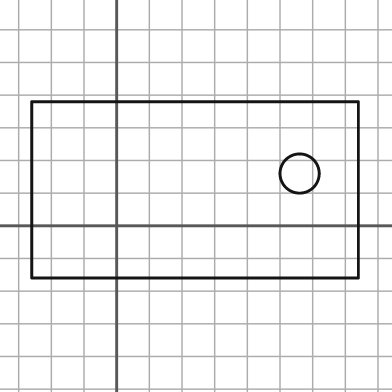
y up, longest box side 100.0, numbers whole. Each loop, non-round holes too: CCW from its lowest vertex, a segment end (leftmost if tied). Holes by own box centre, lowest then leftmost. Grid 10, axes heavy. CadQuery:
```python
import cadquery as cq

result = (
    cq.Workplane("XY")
    .moveTo(-26.0, -16.0)
    .lineTo(74.0, -16.0)
    .lineTo(74.0, 38.0)
    .lineTo(-26.0, 38.0)
    .close()
    .moveTo(56.0, 16.0)
    .circle(6.0)
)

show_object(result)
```